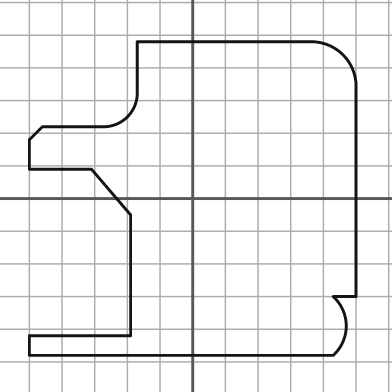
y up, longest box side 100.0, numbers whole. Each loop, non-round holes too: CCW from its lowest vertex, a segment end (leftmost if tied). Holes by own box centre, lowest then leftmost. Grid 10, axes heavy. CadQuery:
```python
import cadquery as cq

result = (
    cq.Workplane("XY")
    .moveTo(-50.0, -48.0)
    .lineTo(43.0, -48.0)
    .threePointArc((47.0, -39.0), (43.0, -30.0))
    .lineTo(50.0, -30.0)
    .lineTo(50.0, 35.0)
    .threePointArc((46.0, 44.0), (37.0, 48.0))
    .lineTo(-17.0, 48.0)
    .lineTo(-17.0, 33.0)
    .threePointArc((-20.0, 25.0), (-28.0, 22.0))
    .lineTo(-46.0, 22.0)
    .lineTo(-50.0, 18.0)
    .lineTo(-50.0, 9.0)
    .lineTo(-31.0, 9.0)
    .lineTo(-19.0, -5.0)
    .lineTo(-19.0, -42.0)
    .lineTo(-50.0, -42.0)
    .close()
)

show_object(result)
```